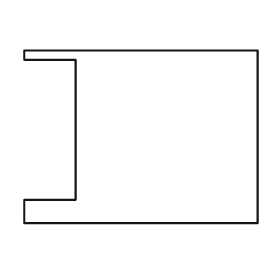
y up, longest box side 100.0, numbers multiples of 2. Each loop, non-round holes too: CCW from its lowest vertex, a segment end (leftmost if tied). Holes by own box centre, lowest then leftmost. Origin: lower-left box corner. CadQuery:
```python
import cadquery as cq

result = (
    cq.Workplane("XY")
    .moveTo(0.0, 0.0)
    .lineTo(100.0, 0.0)
    .lineTo(100.0, 74.0)
    .lineTo(0.0, 74.0)
    .lineTo(0.0, 70.0)
    .lineTo(22.0, 70.0)
    .lineTo(22.0, 10.0)
    .lineTo(0.0, 10.0)
    .close()
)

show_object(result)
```